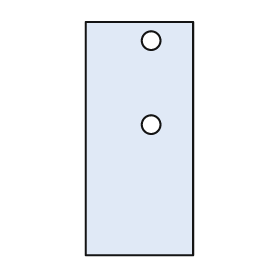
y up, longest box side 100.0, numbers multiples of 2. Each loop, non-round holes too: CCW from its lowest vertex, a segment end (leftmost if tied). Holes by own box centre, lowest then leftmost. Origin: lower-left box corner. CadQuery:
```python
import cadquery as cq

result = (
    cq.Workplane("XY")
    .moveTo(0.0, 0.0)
    .lineTo(46.0, 0.0)
    .lineTo(46.0, 100.0)
    .lineTo(0.0, 100.0)
    .close()
    .moveTo(28.0, 56.0)
    .circle(4.0)
    .moveTo(28.0, 92.0)
    .circle(4.0)
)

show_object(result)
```